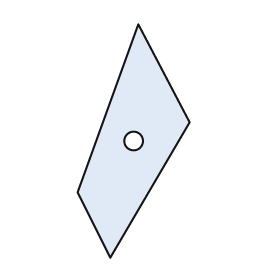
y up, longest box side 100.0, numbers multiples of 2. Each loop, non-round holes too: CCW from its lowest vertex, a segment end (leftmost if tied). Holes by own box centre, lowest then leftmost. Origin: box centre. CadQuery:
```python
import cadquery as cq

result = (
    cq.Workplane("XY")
    .moveTo(-10.0, -50.0)
    .lineTo(24.0, 8.0)
    .lineTo(2.0, 50.0)
    .lineTo(-24.0, -22.0)
    .close()
    .moveTo(0.0, 0.0)
    .circle(4.0)
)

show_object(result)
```